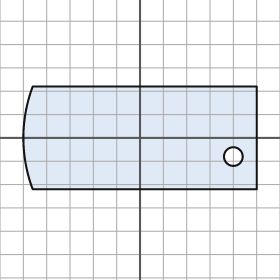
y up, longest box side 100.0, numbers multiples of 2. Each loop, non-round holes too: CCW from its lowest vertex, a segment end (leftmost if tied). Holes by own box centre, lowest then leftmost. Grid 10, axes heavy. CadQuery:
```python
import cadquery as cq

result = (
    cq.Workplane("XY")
    .moveTo(-46.0, -22.0)
    .lineTo(50.0, -22.0)
    .lineTo(50.0, 22.0)
    .lineTo(-46.0, 22.0)
    .threePointArc((-50.0, 0.0), (-46.0, -22.0))
    .close()
    .moveTo(40.0, -8.0)
    .circle(4.0)
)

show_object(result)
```